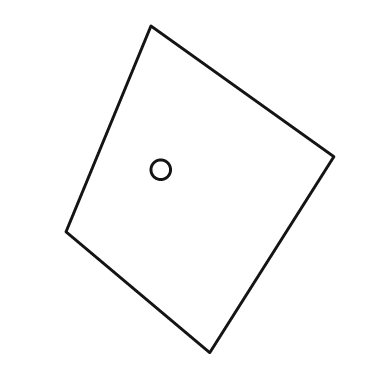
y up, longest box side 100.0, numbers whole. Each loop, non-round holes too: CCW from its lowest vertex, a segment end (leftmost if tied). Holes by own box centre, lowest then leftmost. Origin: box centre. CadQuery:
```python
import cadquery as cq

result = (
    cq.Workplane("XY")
    .moveTo(3.0, -50.0)
    .lineTo(41.0, 10.0)
    .lineTo(-15.0, 50.0)
    .lineTo(-41.0, -13.0)
    .close()
    .moveTo(-12.0, 6.0)
    .circle(3.0)
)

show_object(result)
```